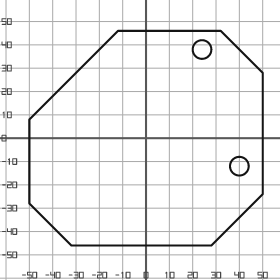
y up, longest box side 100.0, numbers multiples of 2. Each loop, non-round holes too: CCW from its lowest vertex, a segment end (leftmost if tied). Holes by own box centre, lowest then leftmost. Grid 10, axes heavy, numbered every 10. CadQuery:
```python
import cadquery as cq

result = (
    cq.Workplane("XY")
    .moveTo(-32.0, -46.0)
    .lineTo(28.0, -46.0)
    .lineTo(50.0, -24.0)
    .lineTo(50.0, 28.0)
    .lineTo(32.0, 46.0)
    .lineTo(-12.0, 46.0)
    .lineTo(-50.0, 8.0)
    .lineTo(-50.0, -28.0)
    .close()
    .moveTo(40.0, -12.0)
    .circle(4.0)
    .moveTo(24.0, 38.0)
    .circle(4.0)
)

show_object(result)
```